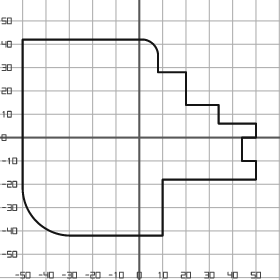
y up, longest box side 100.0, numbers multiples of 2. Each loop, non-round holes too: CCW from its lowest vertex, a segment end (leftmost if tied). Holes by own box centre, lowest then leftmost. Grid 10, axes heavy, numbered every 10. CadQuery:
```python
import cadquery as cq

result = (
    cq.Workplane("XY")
    .moveTo(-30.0, -42.0)
    .lineTo(10.0, -42.0)
    .lineTo(10.0, -18.0)
    .lineTo(50.0, -18.0)
    .lineTo(50.0, -10.0)
    .lineTo(44.0, -10.0)
    .lineTo(44.0, 0.0)
    .lineTo(50.0, 0.0)
    .lineTo(50.0, 6.0)
    .lineTo(34.0, 6.0)
    .lineTo(34.0, 14.0)
    .lineTo(20.0, 14.0)
    .lineTo(20.0, 28.0)
    .lineTo(8.0, 28.0)
    .lineTo(8.0, 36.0)
    .threePointArc((6.0, 40.0), (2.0, 42.0))
    .lineTo(-50.0, 42.0)
    .lineTo(-50.0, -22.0)
    .threePointArc((-44.0, -36.0), (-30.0, -42.0))
    .close()
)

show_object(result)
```